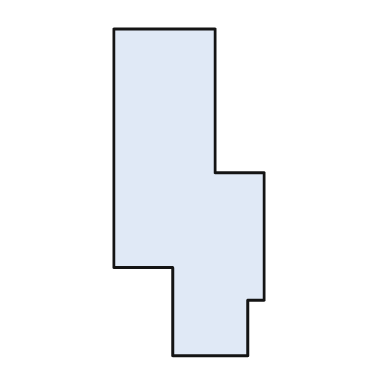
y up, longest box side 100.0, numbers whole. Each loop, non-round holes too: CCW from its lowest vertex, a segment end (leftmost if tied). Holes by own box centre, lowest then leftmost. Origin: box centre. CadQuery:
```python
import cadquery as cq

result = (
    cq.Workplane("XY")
    .moveTo(-5.0, -50.0)
    .lineTo(18.0, -50.0)
    .lineTo(18.0, -33.0)
    .lineTo(23.0, -33.0)
    .lineTo(23.0, 6.0)
    .lineTo(8.0, 6.0)
    .lineTo(8.0, 50.0)
    .lineTo(-23.0, 50.0)
    .lineTo(-23.0, -23.0)
    .lineTo(-5.0, -23.0)
    .close()
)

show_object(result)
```